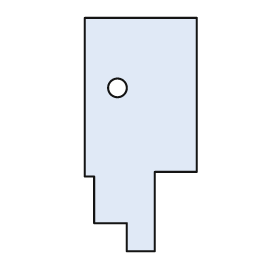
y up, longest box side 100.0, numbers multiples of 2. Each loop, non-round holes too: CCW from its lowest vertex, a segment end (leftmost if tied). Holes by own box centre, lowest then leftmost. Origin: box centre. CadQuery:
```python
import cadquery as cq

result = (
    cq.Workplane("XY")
    .moveTo(-6.0, -50.0)
    .lineTo(6.0, -50.0)
    .lineTo(6.0, -16.0)
    .lineTo(24.0, -16.0)
    .lineTo(24.0, 50.0)
    .lineTo(-24.0, 50.0)
    .lineTo(-24.0, -18.0)
    .lineTo(-20.0, -18.0)
    .lineTo(-20.0, -38.0)
    .lineTo(-6.0, -38.0)
    .close()
    .moveTo(-10.0, 20.0)
    .circle(4.0)
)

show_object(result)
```